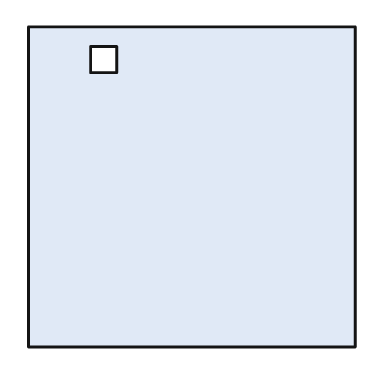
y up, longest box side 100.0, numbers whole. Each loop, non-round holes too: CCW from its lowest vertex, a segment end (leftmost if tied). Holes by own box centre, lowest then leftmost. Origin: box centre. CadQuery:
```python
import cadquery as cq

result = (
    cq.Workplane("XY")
    .moveTo(-50.0, -49.0)
    .lineTo(50.0, -49.0)
    .lineTo(50.0, 49.0)
    .lineTo(-50.0, 49.0)
    .close()
    .moveTo(-31.0, 35.0)
    .lineTo(-23.0, 35.0)
    .lineTo(-23.0, 43.0)
    .lineTo(-31.0, 43.0)
    .close()
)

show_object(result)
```